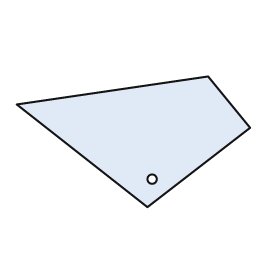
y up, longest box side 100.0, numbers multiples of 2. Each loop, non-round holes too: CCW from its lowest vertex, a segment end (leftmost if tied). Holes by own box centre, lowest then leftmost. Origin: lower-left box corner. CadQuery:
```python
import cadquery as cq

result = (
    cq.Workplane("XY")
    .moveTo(56.0, 0.0)
    .lineTo(100.0, 34.0)
    .lineTo(82.0, 56.0)
    .lineTo(0.0, 44.0)
    .close()
    .moveTo(58.0, 12.0)
    .circle(2.0)
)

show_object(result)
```